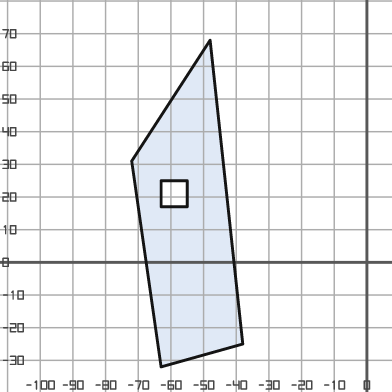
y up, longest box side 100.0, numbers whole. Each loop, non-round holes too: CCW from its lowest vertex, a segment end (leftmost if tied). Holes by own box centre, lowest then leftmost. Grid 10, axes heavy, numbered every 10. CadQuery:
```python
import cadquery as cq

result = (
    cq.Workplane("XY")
    .moveTo(-63.0, -32.0)
    .lineTo(-38.0, -25.0)
    .lineTo(-48.0, 68.0)
    .lineTo(-72.0, 31.0)
    .close()
    .moveTo(-63.0, 17.0)
    .lineTo(-55.0, 17.0)
    .lineTo(-55.0, 25.0)
    .lineTo(-63.0, 25.0)
    .close()
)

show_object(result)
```